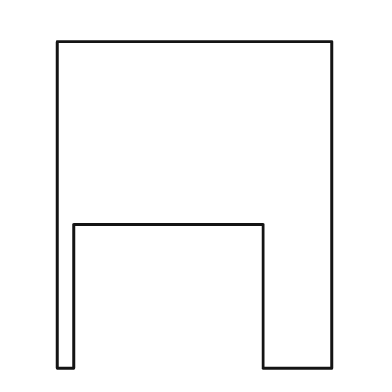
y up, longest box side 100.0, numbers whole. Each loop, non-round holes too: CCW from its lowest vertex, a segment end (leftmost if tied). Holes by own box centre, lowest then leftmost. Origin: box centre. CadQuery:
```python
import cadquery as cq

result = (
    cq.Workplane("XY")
    .moveTo(-42.0, -50.0)
    .lineTo(-37.0, -50.0)
    .lineTo(-37.0, -6.0)
    .lineTo(21.0, -6.0)
    .lineTo(21.0, -50.0)
    .lineTo(42.0, -50.0)
    .lineTo(42.0, 50.0)
    .lineTo(-42.0, 50.0)
    .close()
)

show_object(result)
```